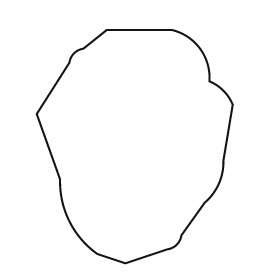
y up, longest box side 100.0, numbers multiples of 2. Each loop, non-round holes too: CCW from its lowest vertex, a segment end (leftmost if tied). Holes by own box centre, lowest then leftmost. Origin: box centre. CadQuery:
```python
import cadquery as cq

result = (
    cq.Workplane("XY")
    .moveTo(-4.0, -50.0)
    .lineTo(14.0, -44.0)
    .threePointArc((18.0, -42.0), (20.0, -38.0))
    .lineTo(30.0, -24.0)
    .threePointArc((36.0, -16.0), (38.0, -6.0))
    .lineTo(42.0, 18.0)
    .threePointArc((38.0, 24.0), (32.0, 28.0))
    .threePointArc((28.0, 42.0), (16.0, 50.0))
    .lineTo(-12.0, 50.0)
    .lineTo(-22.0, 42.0)
    .threePointArc((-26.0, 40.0), (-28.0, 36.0))
    .lineTo(-42.0, 14.0)
    .lineTo(-32.0, -14.0)
    .threePointArc((-28.0, -32.0), (-16.0, -46.0))
    .close()
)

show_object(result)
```